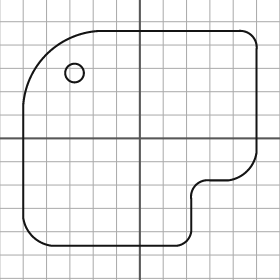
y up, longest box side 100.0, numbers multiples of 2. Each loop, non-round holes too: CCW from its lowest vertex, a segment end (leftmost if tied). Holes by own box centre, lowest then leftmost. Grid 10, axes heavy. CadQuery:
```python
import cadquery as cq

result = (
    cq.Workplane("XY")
    .moveTo(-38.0, -46.0)
    .lineTo(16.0, -46.0)
    .threePointArc((20.0, -44.0), (22.0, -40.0))
    .lineTo(22.0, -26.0)
    .threePointArc((24.0, -20.0), (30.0, -18.0))
    .lineTo(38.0, -18.0)
    .threePointArc((46.0, -14.0), (50.0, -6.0))
    .lineTo(50.0, 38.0)
    .threePointArc((48.0, 44.0), (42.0, 46.0))
    .lineTo(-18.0, 46.0)
    .threePointArc((-40.0, 36.0), (-50.0, 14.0))
    .lineTo(-50.0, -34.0)
    .threePointArc((-46.0, -42.0), (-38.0, -46.0))
    .close()
    .moveTo(-28.0, 28.0)
    .circle(4.0)
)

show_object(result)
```